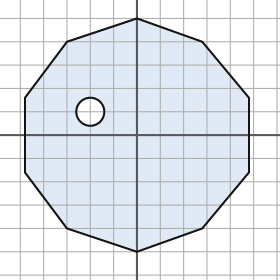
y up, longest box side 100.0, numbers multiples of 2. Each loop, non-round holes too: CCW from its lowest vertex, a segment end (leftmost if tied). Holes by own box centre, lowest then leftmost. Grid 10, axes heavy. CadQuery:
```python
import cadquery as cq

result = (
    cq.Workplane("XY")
    .moveTo(0.0, -50.0)
    .lineTo(28.0, -40.0)
    .lineTo(48.0, -16.0)
    .lineTo(48.0, 16.0)
    .lineTo(28.0, 40.0)
    .lineTo(0.0, 50.0)
    .lineTo(-30.0, 40.0)
    .lineTo(-48.0, 16.0)
    .lineTo(-48.0, -16.0)
    .lineTo(-30.0, -40.0)
    .close()
    .moveTo(-20.0, 10.0)
    .circle(6.0)
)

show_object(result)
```